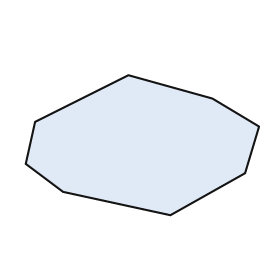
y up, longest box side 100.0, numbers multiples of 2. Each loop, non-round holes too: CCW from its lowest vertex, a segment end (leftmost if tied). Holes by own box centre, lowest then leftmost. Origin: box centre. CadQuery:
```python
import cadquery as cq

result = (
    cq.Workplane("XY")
    .moveTo(12.0, -30.0)
    .lineTo(44.0, -12.0)
    .lineTo(50.0, 8.0)
    .lineTo(30.0, 20.0)
    .lineTo(-6.0, 30.0)
    .lineTo(-46.0, 10.0)
    .lineTo(-50.0, -8.0)
    .lineTo(-34.0, -20.0)
    .close()
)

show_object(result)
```